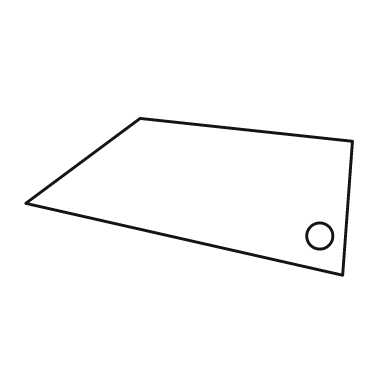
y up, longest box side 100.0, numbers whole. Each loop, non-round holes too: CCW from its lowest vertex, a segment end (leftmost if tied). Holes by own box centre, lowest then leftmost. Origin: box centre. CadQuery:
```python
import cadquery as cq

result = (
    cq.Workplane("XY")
    .moveTo(47.0, -24.0)
    .lineTo(50.0, 17.0)
    .lineTo(-15.0, 24.0)
    .lineTo(-50.0, -2.0)
    .close()
    .moveTo(40.0, -12.0)
    .circle(4.0)
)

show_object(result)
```